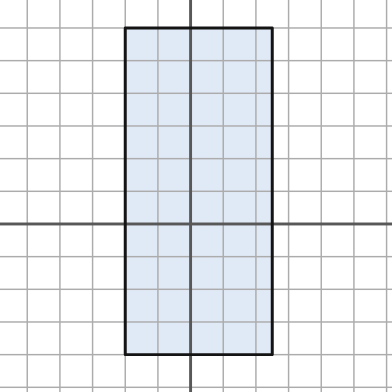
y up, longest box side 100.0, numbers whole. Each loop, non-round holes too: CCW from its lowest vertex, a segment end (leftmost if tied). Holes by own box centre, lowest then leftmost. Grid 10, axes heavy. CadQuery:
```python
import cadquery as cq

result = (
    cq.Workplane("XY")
    .moveTo(-20.0, -40.0)
    .lineTo(25.0, -40.0)
    .lineTo(25.0, 60.0)
    .lineTo(-20.0, 60.0)
    .close()
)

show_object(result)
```